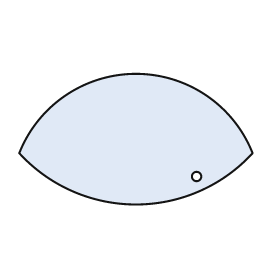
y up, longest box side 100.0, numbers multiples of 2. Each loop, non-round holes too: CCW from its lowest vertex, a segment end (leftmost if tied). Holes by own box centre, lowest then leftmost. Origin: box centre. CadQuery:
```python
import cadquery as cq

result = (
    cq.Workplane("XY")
    .moveTo(-50.0, -6.0)
    .threePointArc((0.0, -28.0), (50.0, -6.0))
    .threePointArc((0.0, 28.0), (-50.0, -6.0))
    .close()
    .moveTo(26.0, -16.0)
    .circle(2.0)
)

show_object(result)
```